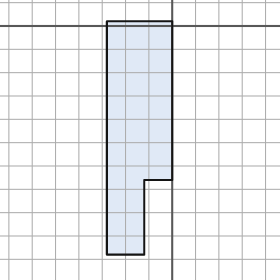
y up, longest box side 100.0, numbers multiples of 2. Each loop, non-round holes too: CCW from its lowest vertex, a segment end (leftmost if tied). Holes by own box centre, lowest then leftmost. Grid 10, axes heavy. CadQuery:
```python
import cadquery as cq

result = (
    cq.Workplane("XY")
    .moveTo(-28.0, -98.0)
    .lineTo(-12.0, -98.0)
    .lineTo(-12.0, -66.0)
    .lineTo(0.0, -66.0)
    .lineTo(0.0, 2.0)
    .lineTo(-28.0, 2.0)
    .close()
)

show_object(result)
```